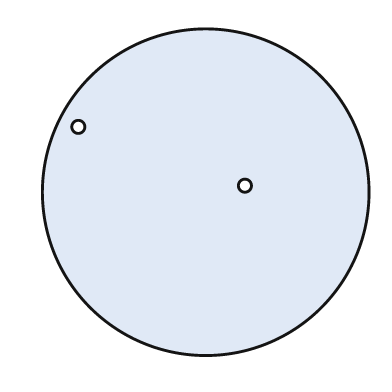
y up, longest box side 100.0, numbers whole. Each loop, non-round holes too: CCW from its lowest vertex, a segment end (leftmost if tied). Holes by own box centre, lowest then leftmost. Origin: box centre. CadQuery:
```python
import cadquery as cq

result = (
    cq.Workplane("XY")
    .moveTo(0.0, 0.0)
    .circle(50.0)
    .moveTo(12.0, 2.0)
    .circle(2.0)
    .moveTo(-39.0, 20.0)
    .circle(2.0)
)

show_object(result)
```